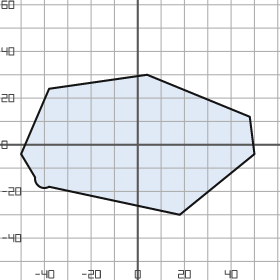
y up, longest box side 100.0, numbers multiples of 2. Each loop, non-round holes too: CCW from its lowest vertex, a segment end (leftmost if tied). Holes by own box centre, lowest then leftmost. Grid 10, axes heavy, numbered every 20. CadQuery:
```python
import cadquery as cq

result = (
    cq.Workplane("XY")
    .moveTo(18.0, -30.0)
    .lineTo(50.0, -4.0)
    .lineTo(48.0, 12.0)
    .lineTo(4.0, 30.0)
    .lineTo(-38.0, 24.0)
    .lineTo(-50.0, -4.0)
    .lineTo(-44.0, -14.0)
    .threePointArc((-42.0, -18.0), (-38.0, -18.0))
    .close()
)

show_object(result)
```